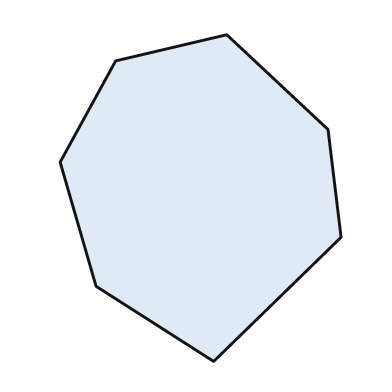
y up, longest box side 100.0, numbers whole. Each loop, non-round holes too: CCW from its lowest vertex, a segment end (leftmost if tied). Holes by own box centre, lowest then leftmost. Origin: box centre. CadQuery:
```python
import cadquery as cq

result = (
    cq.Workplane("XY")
    .moveTo(4.0, -50.0)
    .lineTo(43.0, -12.0)
    .lineTo(39.0, 21.0)
    .lineTo(8.0, 50.0)
    .lineTo(-26.0, 42.0)
    .lineTo(-43.0, 11.0)
    .lineTo(-32.0, -27.0)
    .close()
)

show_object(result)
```